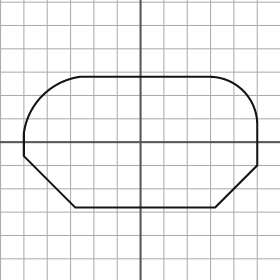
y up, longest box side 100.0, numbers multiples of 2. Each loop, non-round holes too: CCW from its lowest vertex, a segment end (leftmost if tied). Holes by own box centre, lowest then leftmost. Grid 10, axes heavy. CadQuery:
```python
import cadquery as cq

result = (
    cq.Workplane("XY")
    .moveTo(-28.0, -28.0)
    .lineTo(32.0, -28.0)
    .lineTo(50.0, -10.0)
    .lineTo(50.0, 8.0)
    .threePointArc((44.0, 22.0), (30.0, 28.0))
    .lineTo(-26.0, 28.0)
    .threePointArc((-42.0, 20.0), (-50.0, 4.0))
    .lineTo(-50.0, -6.0)
    .close()
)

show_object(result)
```